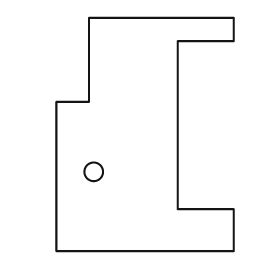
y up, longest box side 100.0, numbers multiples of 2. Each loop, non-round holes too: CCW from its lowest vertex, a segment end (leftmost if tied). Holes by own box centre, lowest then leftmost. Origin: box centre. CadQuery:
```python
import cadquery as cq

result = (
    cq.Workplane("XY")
    .moveTo(-38.0, -50.0)
    .lineTo(38.0, -50.0)
    .lineTo(38.0, -32.0)
    .lineTo(14.0, -32.0)
    .lineTo(14.0, 40.0)
    .lineTo(38.0, 40.0)
    .lineTo(38.0, 50.0)
    .lineTo(-24.0, 50.0)
    .lineTo(-24.0, 14.0)
    .lineTo(-38.0, 14.0)
    .close()
    .moveTo(-22.0, -16.0)
    .circle(4.0)
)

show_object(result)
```